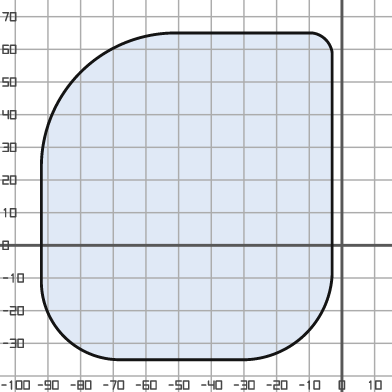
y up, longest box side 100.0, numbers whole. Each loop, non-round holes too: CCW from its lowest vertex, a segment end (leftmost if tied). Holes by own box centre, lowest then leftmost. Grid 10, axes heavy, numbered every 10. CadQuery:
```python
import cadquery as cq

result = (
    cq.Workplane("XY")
    .moveTo(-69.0, -35.0)
    .lineTo(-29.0, -35.0)
    .threePointArc((-11.0, -27.0), (-3.0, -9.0))
    .lineTo(-3.0, 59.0)
    .threePointArc((-5.0, 63.0), (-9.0, 65.0))
    .lineTo(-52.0, 65.0)
    .threePointArc((-80.0, 53.0), (-92.0, 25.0))
    .lineTo(-92.0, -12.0)
    .threePointArc((-85.0, -28.0), (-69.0, -35.0))
    .close()
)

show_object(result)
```